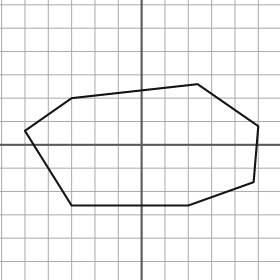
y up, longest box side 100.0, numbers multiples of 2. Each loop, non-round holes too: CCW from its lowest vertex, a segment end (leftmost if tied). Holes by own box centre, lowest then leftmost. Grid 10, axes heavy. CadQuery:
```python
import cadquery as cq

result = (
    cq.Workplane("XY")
    .moveTo(-30.0, -26.0)
    .lineTo(20.0, -26.0)
    .lineTo(48.0, -16.0)
    .lineTo(50.0, 8.0)
    .lineTo(24.0, 26.0)
    .lineTo(-30.0, 20.0)
    .lineTo(-50.0, 6.0)
    .close()
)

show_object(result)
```